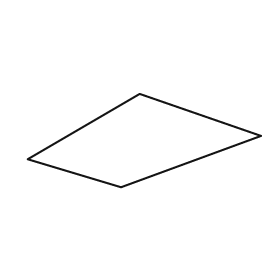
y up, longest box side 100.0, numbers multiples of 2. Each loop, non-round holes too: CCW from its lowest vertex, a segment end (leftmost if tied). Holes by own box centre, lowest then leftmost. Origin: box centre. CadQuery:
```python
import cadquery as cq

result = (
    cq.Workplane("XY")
    .moveTo(-10.0, -20.0)
    .lineTo(50.0, 2.0)
    .lineTo(-2.0, 20.0)
    .lineTo(-50.0, -8.0)
    .close()
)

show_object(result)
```